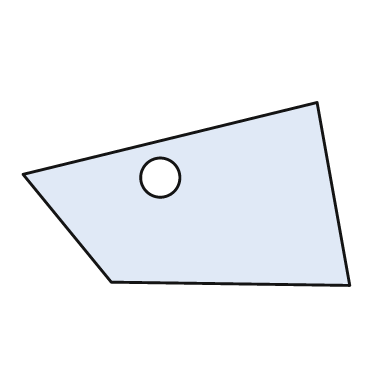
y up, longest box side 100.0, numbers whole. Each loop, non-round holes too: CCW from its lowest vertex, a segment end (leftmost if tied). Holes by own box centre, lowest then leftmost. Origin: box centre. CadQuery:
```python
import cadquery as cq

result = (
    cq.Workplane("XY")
    .moveTo(50.0, -28.0)
    .lineTo(40.0, 28.0)
    .lineTo(-50.0, 6.0)
    .lineTo(-23.0, -27.0)
    .close()
    .moveTo(-8.0, 5.0)
    .circle(6.0)
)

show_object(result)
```